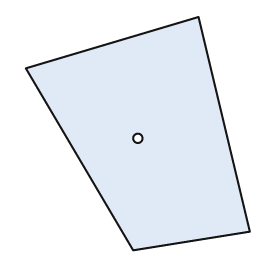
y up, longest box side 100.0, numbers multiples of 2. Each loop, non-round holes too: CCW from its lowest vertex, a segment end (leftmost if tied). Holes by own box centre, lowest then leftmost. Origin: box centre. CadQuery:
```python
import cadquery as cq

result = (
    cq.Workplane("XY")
    .moveTo(-2.0, -50.0)
    .lineTo(48.0, -42.0)
    .lineTo(26.0, 50.0)
    .lineTo(-48.0, 28.0)
    .close()
    .moveTo(0.0, -2.0)
    .circle(2.0)
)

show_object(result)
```